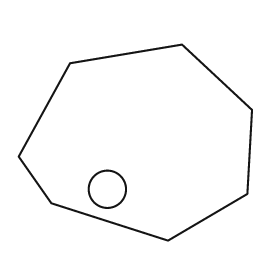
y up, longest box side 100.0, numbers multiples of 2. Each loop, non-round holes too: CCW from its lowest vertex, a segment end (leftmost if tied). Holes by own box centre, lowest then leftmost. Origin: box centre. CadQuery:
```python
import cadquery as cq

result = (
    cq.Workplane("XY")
    .moveTo(14.0, -42.0)
    .lineTo(48.0, -22.0)
    .lineTo(50.0, 14.0)
    .lineTo(20.0, 42.0)
    .lineTo(-28.0, 34.0)
    .lineTo(-50.0, -6.0)
    .lineTo(-36.0, -26.0)
    .close()
    .moveTo(-12.0, -20.0)
    .circle(8.0)
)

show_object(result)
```